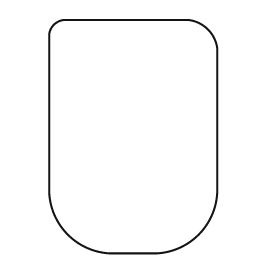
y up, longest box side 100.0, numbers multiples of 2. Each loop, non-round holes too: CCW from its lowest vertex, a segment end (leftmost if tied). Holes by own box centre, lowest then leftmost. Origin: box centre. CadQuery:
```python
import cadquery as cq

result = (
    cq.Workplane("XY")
    .moveTo(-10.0, -50.0)
    .lineTo(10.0, -50.0)
    .threePointArc((28.0, -42.0), (36.0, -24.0))
    .lineTo(36.0, 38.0)
    .threePointArc((32.0, 46.0), (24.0, 50.0))
    .lineTo(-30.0, 50.0)
    .threePointArc((-34.0, 48.0), (-36.0, 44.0))
    .lineTo(-36.0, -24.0)
    .threePointArc((-28.0, -42.0), (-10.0, -50.0))
    .close()
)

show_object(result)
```